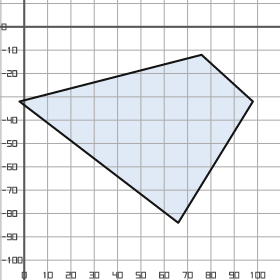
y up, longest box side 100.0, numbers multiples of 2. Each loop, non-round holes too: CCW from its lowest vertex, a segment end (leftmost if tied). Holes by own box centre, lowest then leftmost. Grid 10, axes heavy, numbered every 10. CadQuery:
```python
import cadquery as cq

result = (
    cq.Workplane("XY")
    .moveTo(66.0, -84.0)
    .lineTo(98.0, -32.0)
    .lineTo(76.0, -12.0)
    .lineTo(-2.0, -32.0)
    .close()
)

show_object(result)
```